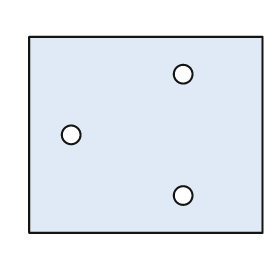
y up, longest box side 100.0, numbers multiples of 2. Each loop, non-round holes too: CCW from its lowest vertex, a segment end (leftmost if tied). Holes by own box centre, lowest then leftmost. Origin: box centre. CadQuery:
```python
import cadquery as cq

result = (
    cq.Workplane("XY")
    .moveTo(-50.0, -42.0)
    .lineTo(50.0, -42.0)
    .lineTo(50.0, 42.0)
    .lineTo(-50.0, 42.0)
    .close()
    .moveTo(16.0, -26.0)
    .circle(4.0)
    .moveTo(-32.0, 0.0)
    .circle(4.0)
    .moveTo(16.0, 26.0)
    .circle(4.0)
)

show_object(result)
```